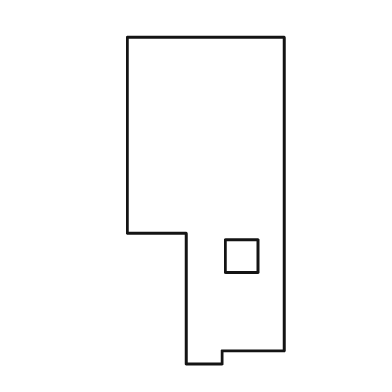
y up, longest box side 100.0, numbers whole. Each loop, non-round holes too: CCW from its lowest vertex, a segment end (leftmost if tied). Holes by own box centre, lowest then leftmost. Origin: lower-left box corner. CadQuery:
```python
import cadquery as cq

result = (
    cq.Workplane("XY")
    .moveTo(18.0, 0.0)
    .lineTo(29.0, 0.0)
    .lineTo(29.0, 4.0)
    .lineTo(48.0, 4.0)
    .lineTo(48.0, 100.0)
    .lineTo(0.0, 100.0)
    .lineTo(0.0, 40.0)
    .lineTo(18.0, 40.0)
    .close()
    .moveTo(30.0, 28.0)
    .lineTo(40.0, 28.0)
    .lineTo(40.0, 38.0)
    .lineTo(30.0, 38.0)
    .close()
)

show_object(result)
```